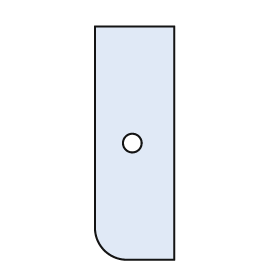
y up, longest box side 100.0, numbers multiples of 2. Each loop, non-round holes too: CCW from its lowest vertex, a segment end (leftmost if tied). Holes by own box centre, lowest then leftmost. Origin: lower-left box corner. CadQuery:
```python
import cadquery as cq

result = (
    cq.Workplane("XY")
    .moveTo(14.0, 0.0)
    .lineTo(34.0, 0.0)
    .lineTo(34.0, 100.0)
    .lineTo(0.0, 100.0)
    .lineTo(0.0, 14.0)
    .threePointArc((4.0, 4.0), (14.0, 0.0))
    .close()
    .moveTo(16.0, 50.0)
    .circle(4.0)
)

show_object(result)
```